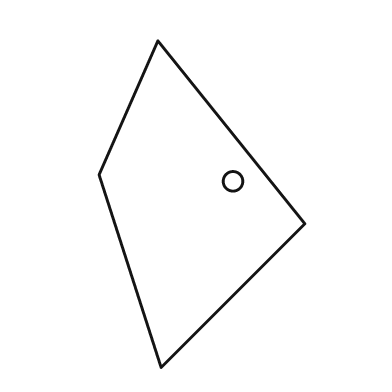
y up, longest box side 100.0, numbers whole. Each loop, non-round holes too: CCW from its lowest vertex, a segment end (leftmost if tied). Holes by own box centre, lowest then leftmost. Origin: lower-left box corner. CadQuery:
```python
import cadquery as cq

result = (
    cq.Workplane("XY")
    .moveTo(19.0, 0.0)
    .lineTo(63.0, 44.0)
    .lineTo(18.0, 100.0)
    .lineTo(0.0, 59.0)
    .close()
    .moveTo(41.0, 57.0)
    .circle(3.0)
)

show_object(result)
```